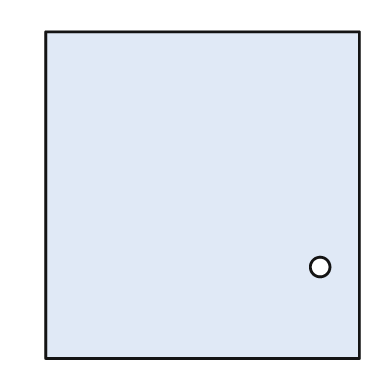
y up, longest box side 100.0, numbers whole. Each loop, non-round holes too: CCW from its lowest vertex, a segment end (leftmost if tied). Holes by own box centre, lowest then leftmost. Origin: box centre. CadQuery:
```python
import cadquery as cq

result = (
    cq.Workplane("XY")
    .moveTo(-48.0, -50.0)
    .lineTo(48.0, -50.0)
    .lineTo(48.0, 50.0)
    .lineTo(-48.0, 50.0)
    .close()
    .moveTo(36.0, -22.0)
    .circle(3.0)
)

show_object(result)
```